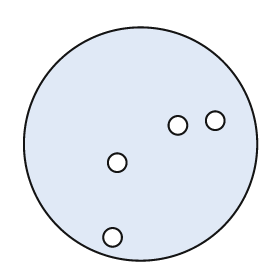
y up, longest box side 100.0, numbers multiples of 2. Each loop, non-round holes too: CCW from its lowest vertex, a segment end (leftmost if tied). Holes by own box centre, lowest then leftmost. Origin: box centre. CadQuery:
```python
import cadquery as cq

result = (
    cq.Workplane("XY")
    .moveTo(0.0, 0.0)
    .circle(50.0)
    .moveTo(-12.0, -40.0)
    .circle(4.0)
    .moveTo(-10.0, -8.0)
    .circle(4.0)
    .moveTo(16.0, 8.0)
    .circle(4.0)
    .moveTo(32.0, 10.0)
    .circle(4.0)
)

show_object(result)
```